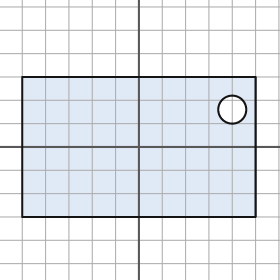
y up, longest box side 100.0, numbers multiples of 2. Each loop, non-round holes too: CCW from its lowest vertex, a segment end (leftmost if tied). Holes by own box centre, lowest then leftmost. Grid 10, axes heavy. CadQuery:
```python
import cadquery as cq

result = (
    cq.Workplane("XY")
    .moveTo(-50.0, -30.0)
    .lineTo(50.0, -30.0)
    .lineTo(50.0, 30.0)
    .lineTo(-50.0, 30.0)
    .close()
    .moveTo(40.0, 16.0)
    .circle(6.0)
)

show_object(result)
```